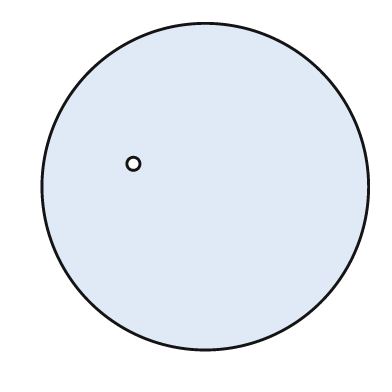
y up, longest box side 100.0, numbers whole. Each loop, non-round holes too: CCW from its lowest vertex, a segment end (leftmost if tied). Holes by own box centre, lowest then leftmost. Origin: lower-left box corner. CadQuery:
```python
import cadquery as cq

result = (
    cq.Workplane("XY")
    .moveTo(50.0, 50.0)
    .circle(50.0)
    .moveTo(28.0, 57.0)
    .circle(2.0)
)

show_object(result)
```